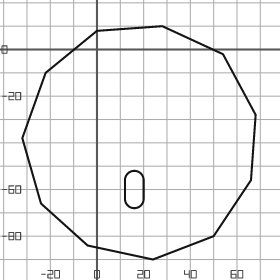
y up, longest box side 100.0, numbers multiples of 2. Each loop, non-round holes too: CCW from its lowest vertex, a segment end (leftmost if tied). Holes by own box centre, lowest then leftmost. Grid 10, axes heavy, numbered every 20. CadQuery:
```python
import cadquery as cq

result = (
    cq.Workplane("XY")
    .moveTo(24.0, -90.0)
    .lineTo(50.0, -80.0)
    .lineTo(66.0, -56.0)
    .lineTo(68.0, -28.0)
    .lineTo(54.0, -2.0)
    .lineTo(28.0, 10.0)
    .lineTo(0.0, 8.0)
    .lineTo(-22.0, -10.0)
    .lineTo(-32.0, -38.0)
    .lineTo(-24.0, -66.0)
    .lineTo(-4.0, -84.0)
    .close()
    .moveTo(12.0, -64.0)
    .threePointArc((16.0, -68.0), (20.0, -64.0))
    .lineTo(20.0, -56.0)
    .threePointArc((16.0, -52.0), (12.0, -56.0))
    .close()
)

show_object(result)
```